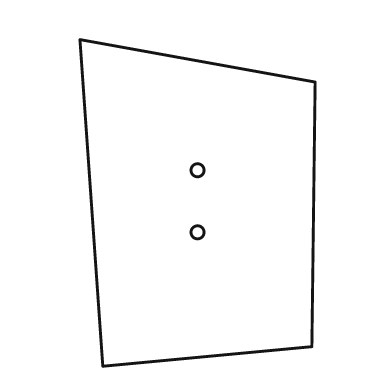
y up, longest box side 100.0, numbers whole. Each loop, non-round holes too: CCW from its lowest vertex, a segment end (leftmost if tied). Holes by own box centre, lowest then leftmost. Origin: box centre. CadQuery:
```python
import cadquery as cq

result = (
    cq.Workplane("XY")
    .moveTo(-29.0, -50.0)
    .lineTo(35.0, -44.0)
    .lineTo(36.0, 37.0)
    .lineTo(-36.0, 50.0)
    .close()
    .moveTo(0.0, -9.0)
    .circle(2.0)
    .moveTo(0.0, 10.0)
    .circle(2.0)
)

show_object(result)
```